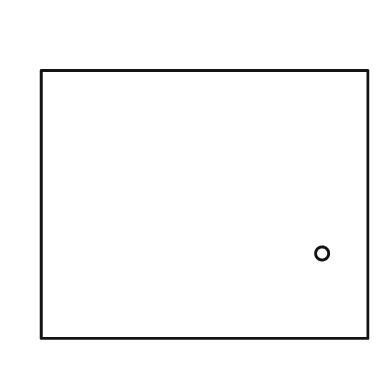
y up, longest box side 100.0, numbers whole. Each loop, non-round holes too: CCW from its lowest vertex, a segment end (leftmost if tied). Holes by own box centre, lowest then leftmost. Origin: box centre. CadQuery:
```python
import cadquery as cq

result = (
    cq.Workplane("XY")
    .moveTo(-50.0, -41.0)
    .lineTo(50.0, -41.0)
    .lineTo(50.0, 41.0)
    .lineTo(-50.0, 41.0)
    .close()
    .moveTo(36.0, -15.0)
    .circle(2.0)
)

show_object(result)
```